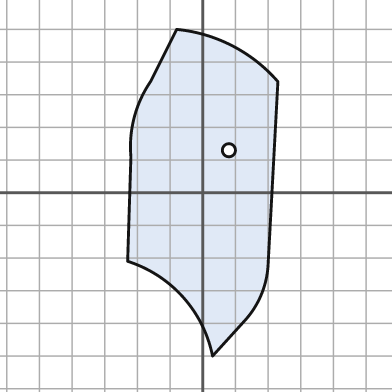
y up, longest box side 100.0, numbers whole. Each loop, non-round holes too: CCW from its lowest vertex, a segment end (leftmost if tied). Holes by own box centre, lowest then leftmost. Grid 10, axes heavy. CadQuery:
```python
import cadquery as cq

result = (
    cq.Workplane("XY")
    .moveTo(3.0, -50.0)
    .lineTo(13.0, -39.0)
    .threePointArc((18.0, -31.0), (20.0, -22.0))
    .lineTo(23.0, 34.0)
    .threePointArc((9.0, 45.0), (-8.0, 50.0))
    .lineTo(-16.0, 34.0)
    .threePointArc((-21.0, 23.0), (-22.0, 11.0))
    .lineTo(-23.0, -21.0)
    .threePointArc((-6.0, -32.0), (3.0, -50.0))
    .close()
    .moveTo(8.0, 13.0)
    .circle(2.0)
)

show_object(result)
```